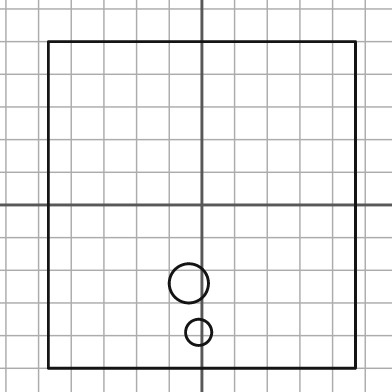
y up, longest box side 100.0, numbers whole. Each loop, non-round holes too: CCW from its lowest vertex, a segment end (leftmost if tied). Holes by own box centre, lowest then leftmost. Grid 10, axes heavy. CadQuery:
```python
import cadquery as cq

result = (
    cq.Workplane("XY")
    .moveTo(-47.0, -50.0)
    .lineTo(47.0, -50.0)
    .lineTo(47.0, 50.0)
    .lineTo(-47.0, 50.0)
    .close()
    .moveTo(-1.0, -39.0)
    .circle(4.0)
    .moveTo(-4.0, -24.0)
    .circle(6.0)
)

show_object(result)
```